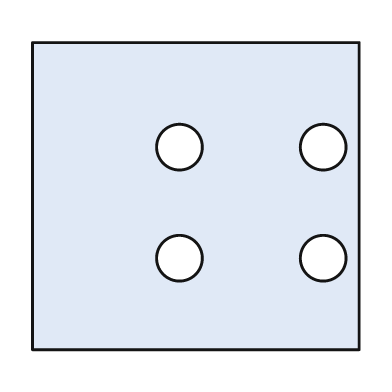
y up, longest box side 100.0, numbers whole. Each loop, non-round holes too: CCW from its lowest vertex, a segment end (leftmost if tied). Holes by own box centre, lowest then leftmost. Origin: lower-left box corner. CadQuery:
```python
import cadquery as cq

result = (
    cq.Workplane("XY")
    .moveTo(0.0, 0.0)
    .lineTo(100.0, 0.0)
    .lineTo(100.0, 94.0)
    .lineTo(0.0, 94.0)
    .close()
    .moveTo(45.0, 28.0)
    .circle(7.0)
    .moveTo(89.0, 28.0)
    .circle(7.0)
    .moveTo(45.0, 62.0)
    .circle(7.0)
    .moveTo(89.0, 62.0)
    .circle(7.0)
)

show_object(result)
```